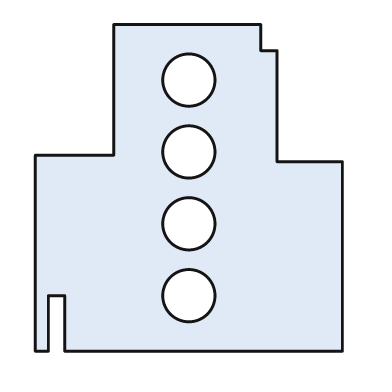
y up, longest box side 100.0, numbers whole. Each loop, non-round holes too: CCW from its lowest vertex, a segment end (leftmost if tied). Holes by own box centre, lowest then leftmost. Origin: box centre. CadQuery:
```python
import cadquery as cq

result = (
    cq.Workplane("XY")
    .moveTo(-47.0, -50.0)
    .lineTo(-43.0, -50.0)
    .lineTo(-43.0, -33.0)
    .lineTo(-38.0, -33.0)
    .lineTo(-38.0, -50.0)
    .lineTo(47.0, -50.0)
    .lineTo(47.0, 8.0)
    .lineTo(27.0, 8.0)
    .lineTo(27.0, 42.0)
    .lineTo(22.0, 42.0)
    .lineTo(22.0, 50.0)
    .lineTo(-23.0, 50.0)
    .lineTo(-23.0, 10.0)
    .lineTo(-47.0, 10.0)
    .close()
    .moveTo(0.0, -33.0)
    .circle(8.0)
    .moveTo(0.0, -11.0)
    .circle(8.0)
    .moveTo(0.0, 11.0)
    .circle(8.0)
    .moveTo(0.0, 33.0)
    .circle(8.0)
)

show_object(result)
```